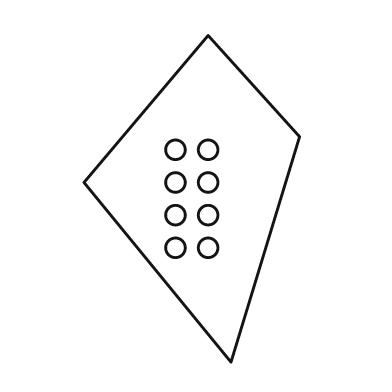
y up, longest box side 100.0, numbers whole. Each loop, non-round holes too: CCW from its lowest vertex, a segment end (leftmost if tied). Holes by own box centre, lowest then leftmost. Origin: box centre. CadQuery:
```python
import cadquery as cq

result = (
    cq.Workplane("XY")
    .moveTo(12.0, -50.0)
    .lineTo(33.0, 19.0)
    .lineTo(5.0, 50.0)
    .lineTo(-33.0, 5.0)
    .close()
    .moveTo(-5.0, -15.0)
    .circle(3.0)
    .moveTo(5.0, -15.0)
    .circle(3.0)
    .moveTo(-5.0, -5.0)
    .circle(3.0)
    .moveTo(5.0, -5.0)
    .circle(3.0)
    .moveTo(-5.0, 5.0)
    .circle(3.0)
    .moveTo(5.0, 5.0)
    .circle(3.0)
    .moveTo(-5.0, 15.0)
    .circle(3.0)
    .moveTo(5.0, 15.0)
    .circle(3.0)
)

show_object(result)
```